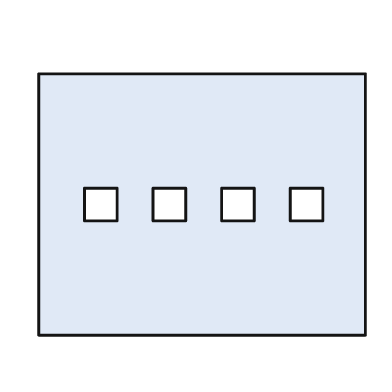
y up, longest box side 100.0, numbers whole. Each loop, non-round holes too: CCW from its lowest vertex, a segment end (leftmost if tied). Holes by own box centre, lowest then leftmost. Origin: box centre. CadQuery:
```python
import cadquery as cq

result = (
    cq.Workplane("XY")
    .moveTo(-50.0, -40.0)
    .lineTo(50.0, -40.0)
    .lineTo(50.0, 40.0)
    .lineTo(-50.0, 40.0)
    .close()
    .moveTo(-36.0, -5.0)
    .lineTo(-26.0, -5.0)
    .lineTo(-26.0, 5.0)
    .lineTo(-36.0, 5.0)
    .close()
    .moveTo(-15.0, -5.0)
    .lineTo(-5.0, -5.0)
    .lineTo(-5.0, 5.0)
    .lineTo(-15.0, 5.0)
    .close()
    .moveTo(6.0, -5.0)
    .lineTo(16.0, -5.0)
    .lineTo(16.0, 5.0)
    .lineTo(6.0, 5.0)
    .close()
    .moveTo(27.0, -5.0)
    .lineTo(37.0, -5.0)
    .lineTo(37.0, 5.0)
    .lineTo(27.0, 5.0)
    .close()
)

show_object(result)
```